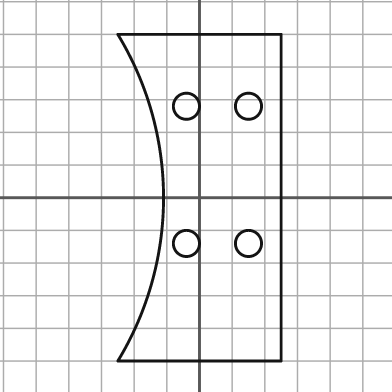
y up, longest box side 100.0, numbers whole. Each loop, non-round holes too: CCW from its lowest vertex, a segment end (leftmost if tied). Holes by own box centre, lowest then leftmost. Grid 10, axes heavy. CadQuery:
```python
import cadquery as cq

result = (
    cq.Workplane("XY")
    .moveTo(-25.0, -50.0)
    .lineTo(25.0, -50.0)
    .lineTo(25.0, 50.0)
    .lineTo(-25.0, 50.0)
    .threePointArc((-11.0, 0.0), (-25.0, -50.0))
    .close()
    .moveTo(-4.0, -14.0)
    .circle(4.0)
    .moveTo(15.0, -14.0)
    .circle(4.0)
    .moveTo(-4.0, 28.0)
    .circle(4.0)
    .moveTo(15.0, 28.0)
    .circle(4.0)
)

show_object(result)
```